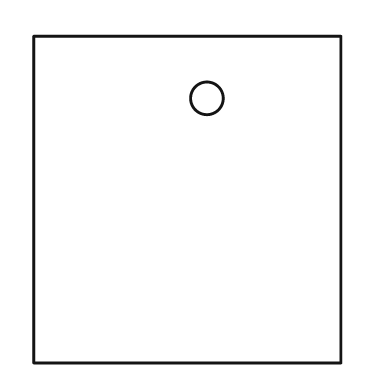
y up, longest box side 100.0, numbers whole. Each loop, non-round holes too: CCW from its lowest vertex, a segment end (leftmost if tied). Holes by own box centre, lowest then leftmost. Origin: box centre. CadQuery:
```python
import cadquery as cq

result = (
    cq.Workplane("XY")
    .moveTo(-47.0, -50.0)
    .lineTo(47.0, -50.0)
    .lineTo(47.0, 50.0)
    .lineTo(-47.0, 50.0)
    .close()
    .moveTo(6.0, 31.0)
    .circle(5.0)
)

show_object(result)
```